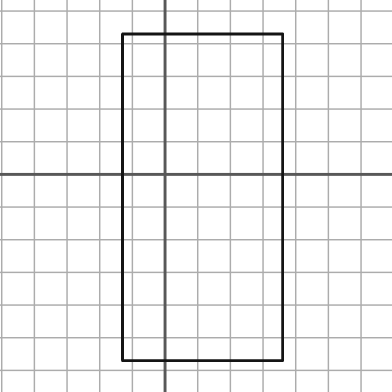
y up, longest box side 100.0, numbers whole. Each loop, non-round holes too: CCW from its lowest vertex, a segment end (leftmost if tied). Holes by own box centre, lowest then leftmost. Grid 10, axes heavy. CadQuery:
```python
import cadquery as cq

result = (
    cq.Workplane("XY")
    .moveTo(-13.0, -57.0)
    .lineTo(36.0, -57.0)
    .lineTo(36.0, 43.0)
    .lineTo(-13.0, 43.0)
    .close()
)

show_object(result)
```